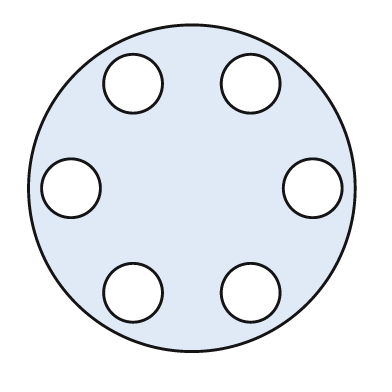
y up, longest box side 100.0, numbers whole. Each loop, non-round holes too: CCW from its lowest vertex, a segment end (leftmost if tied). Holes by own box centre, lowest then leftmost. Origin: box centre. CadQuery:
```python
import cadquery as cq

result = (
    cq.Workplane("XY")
    .moveTo(0.0, 0.0)
    .circle(50.0)
    .moveTo(-18.0, -32.0)
    .circle(9.0)
    .moveTo(18.0, -32.0)
    .circle(9.0)
    .moveTo(-37.0, 0.0)
    .circle(9.0)
    .moveTo(37.0, 0.0)
    .circle(9.0)
    .moveTo(-18.0, 32.0)
    .circle(9.0)
    .moveTo(18.0, 32.0)
    .circle(9.0)
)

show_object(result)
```